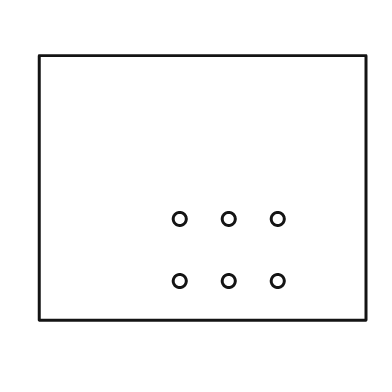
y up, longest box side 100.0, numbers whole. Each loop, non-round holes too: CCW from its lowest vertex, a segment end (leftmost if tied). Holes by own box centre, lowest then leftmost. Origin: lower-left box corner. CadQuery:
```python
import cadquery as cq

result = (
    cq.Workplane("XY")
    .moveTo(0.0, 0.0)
    .lineTo(100.0, 0.0)
    .lineTo(100.0, 81.0)
    .lineTo(0.0, 81.0)
    .close()
    .moveTo(43.0, 12.0)
    .circle(2.0)
    .moveTo(58.0, 12.0)
    .circle(2.0)
    .moveTo(73.0, 12.0)
    .circle(2.0)
    .moveTo(43.0, 31.0)
    .circle(2.0)
    .moveTo(58.0, 31.0)
    .circle(2.0)
    .moveTo(73.0, 31.0)
    .circle(2.0)
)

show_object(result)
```